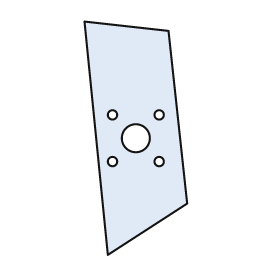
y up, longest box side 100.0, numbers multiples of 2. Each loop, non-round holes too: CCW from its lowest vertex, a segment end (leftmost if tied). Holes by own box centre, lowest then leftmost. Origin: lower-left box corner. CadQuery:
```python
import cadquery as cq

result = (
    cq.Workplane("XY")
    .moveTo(10.0, 0.0)
    .lineTo(44.0, 22.0)
    .lineTo(36.0, 96.0)
    .lineTo(0.0, 100.0)
    .close()
    .moveTo(12.0, 40.0)
    .circle(2.0)
    .moveTo(32.0, 40.0)
    .circle(2.0)
    .moveTo(22.0, 50.0)
    .circle(6.0)
    .moveTo(12.0, 60.0)
    .circle(2.0)
    .moveTo(32.0, 60.0)
    .circle(2.0)
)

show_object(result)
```